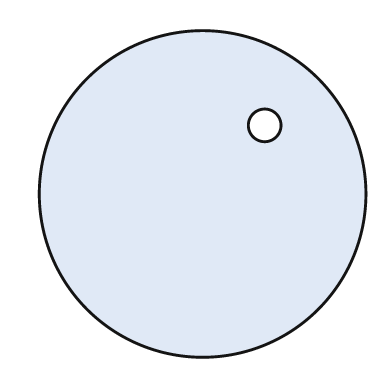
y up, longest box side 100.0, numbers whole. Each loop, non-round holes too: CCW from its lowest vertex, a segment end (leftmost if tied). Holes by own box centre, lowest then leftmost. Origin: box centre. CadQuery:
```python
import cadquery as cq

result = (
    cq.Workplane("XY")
    .moveTo(0.0, 0.0)
    .circle(50.0)
    .moveTo(19.0, 21.0)
    .circle(5.0)
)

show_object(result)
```